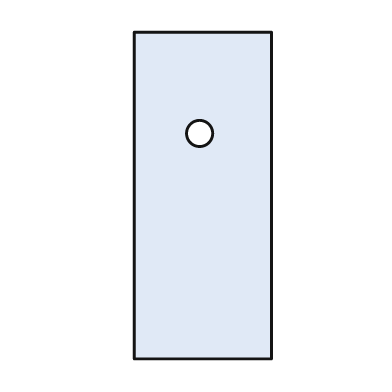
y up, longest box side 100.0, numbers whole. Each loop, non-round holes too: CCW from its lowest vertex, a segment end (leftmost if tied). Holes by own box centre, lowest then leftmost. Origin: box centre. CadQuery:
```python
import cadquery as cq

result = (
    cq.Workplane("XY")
    .moveTo(-21.0, -50.0)
    .lineTo(21.0, -50.0)
    .lineTo(21.0, 50.0)
    .lineTo(-21.0, 50.0)
    .close()
    .moveTo(-1.0, 19.0)
    .circle(4.0)
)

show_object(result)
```